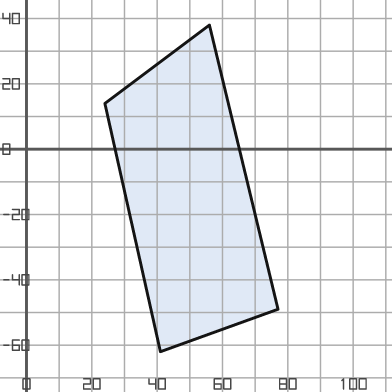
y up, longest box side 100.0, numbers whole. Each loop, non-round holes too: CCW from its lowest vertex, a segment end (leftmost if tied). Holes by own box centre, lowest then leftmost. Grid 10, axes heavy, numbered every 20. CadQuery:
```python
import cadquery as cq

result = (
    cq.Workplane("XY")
    .moveTo(41.0, -62.0)
    .lineTo(77.0, -49.0)
    .lineTo(56.0, 38.0)
    .lineTo(24.0, 14.0)
    .close()
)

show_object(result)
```